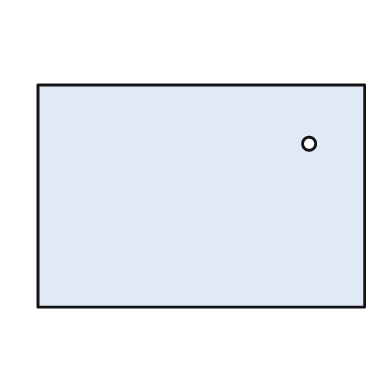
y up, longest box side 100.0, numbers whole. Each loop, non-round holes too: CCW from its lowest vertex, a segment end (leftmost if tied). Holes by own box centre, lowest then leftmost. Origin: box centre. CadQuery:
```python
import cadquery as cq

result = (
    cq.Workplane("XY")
    .moveTo(-50.0, -34.0)
    .lineTo(50.0, -34.0)
    .lineTo(50.0, 34.0)
    .lineTo(-50.0, 34.0)
    .close()
    .moveTo(33.0, 16.0)
    .circle(2.0)
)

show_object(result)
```